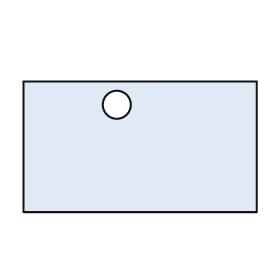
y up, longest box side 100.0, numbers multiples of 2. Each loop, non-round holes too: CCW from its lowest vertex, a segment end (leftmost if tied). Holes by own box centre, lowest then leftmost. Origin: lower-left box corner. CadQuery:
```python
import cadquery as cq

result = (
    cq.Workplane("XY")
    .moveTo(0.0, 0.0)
    .lineTo(100.0, 0.0)
    .lineTo(100.0, 56.0)
    .lineTo(0.0, 56.0)
    .close()
    .moveTo(40.0, 46.0)
    .circle(6.0)
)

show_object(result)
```